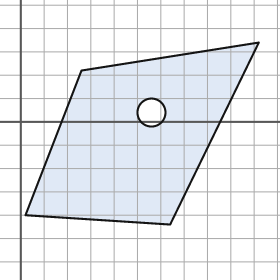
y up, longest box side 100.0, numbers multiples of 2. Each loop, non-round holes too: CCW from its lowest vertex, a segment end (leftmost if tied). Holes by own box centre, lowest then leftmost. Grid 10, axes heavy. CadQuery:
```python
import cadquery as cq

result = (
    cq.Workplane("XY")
    .moveTo(64.0, -44.0)
    .lineTo(102.0, 34.0)
    .lineTo(26.0, 22.0)
    .lineTo(2.0, -40.0)
    .close()
    .moveTo(56.0, 4.0)
    .circle(6.0)
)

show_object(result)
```